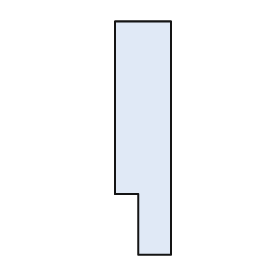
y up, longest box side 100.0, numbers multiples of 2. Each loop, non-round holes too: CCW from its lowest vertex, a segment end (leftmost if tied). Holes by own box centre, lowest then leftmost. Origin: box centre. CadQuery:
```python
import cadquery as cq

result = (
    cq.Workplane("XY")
    .moveTo(-2.0, -50.0)
    .lineTo(12.0, -50.0)
    .lineTo(12.0, 50.0)
    .lineTo(-12.0, 50.0)
    .lineTo(-12.0, -24.0)
    .lineTo(-2.0, -24.0)
    .close()
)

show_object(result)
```